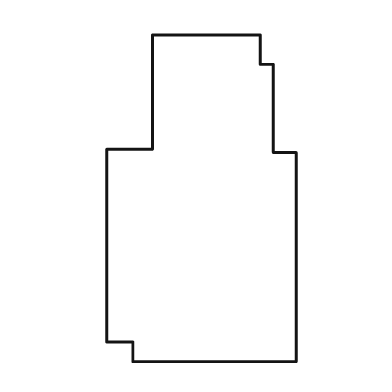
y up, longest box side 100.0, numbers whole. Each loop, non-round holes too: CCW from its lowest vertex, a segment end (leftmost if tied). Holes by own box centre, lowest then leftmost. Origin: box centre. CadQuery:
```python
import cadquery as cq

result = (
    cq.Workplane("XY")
    .moveTo(-21.0, -50.0)
    .lineTo(29.0, -50.0)
    .lineTo(29.0, 14.0)
    .lineTo(22.0, 14.0)
    .lineTo(22.0, 41.0)
    .lineTo(18.0, 41.0)
    .lineTo(18.0, 50.0)
    .lineTo(-15.0, 50.0)
    .lineTo(-15.0, 15.0)
    .lineTo(-29.0, 15.0)
    .lineTo(-29.0, -44.0)
    .lineTo(-21.0, -44.0)
    .close()
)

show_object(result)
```